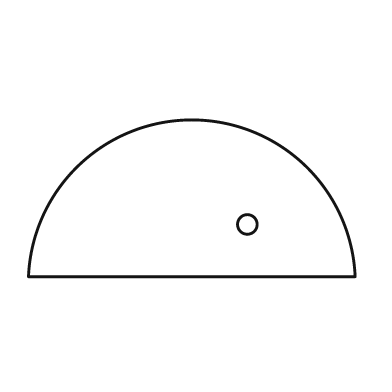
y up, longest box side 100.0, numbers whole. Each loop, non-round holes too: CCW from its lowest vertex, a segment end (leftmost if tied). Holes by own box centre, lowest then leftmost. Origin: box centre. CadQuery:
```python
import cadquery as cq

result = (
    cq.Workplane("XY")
    .moveTo(-50.0, -24.0)
    .lineTo(50.0, -24.0)
    .threePointArc((0.0, 24.0), (-50.0, -24.0))
    .close()
    .moveTo(17.0, -8.0)
    .circle(3.0)
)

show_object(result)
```